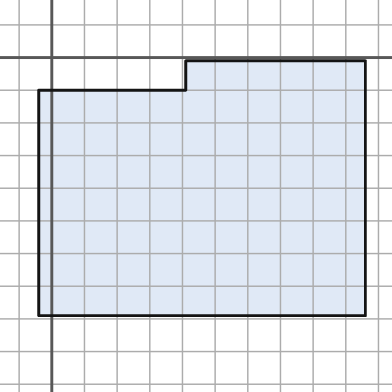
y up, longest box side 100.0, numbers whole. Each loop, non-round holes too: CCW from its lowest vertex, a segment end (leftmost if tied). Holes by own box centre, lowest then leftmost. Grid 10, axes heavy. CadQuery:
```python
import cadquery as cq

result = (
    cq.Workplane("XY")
    .moveTo(-4.0, -79.0)
    .lineTo(96.0, -79.0)
    .lineTo(96.0, -1.0)
    .lineTo(41.0, -1.0)
    .lineTo(41.0, -10.0)
    .lineTo(-4.0, -10.0)
    .close()
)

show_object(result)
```